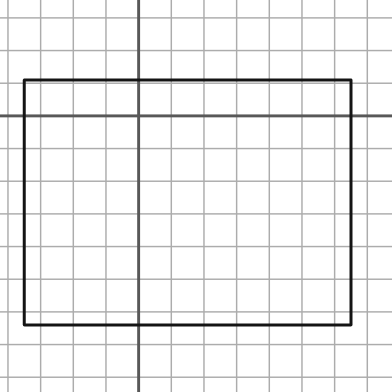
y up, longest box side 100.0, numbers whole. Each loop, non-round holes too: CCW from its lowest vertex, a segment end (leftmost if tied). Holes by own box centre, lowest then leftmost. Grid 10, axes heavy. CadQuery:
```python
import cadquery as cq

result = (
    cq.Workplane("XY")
    .moveTo(-35.0, -64.0)
    .lineTo(65.0, -64.0)
    .lineTo(65.0, 11.0)
    .lineTo(-35.0, 11.0)
    .close()
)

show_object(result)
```